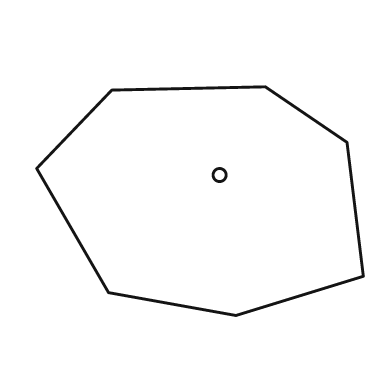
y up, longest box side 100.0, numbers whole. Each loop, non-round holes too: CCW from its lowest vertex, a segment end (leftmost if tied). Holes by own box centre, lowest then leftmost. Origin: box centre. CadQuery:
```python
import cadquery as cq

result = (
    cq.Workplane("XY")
    .moveTo(11.0, -35.0)
    .lineTo(50.0, -23.0)
    .lineTo(45.0, 18.0)
    .lineTo(20.0, 35.0)
    .lineTo(-27.0, 34.0)
    .lineTo(-50.0, 10.0)
    .lineTo(-28.0, -28.0)
    .close()
    .moveTo(6.0, 8.0)
    .circle(2.0)
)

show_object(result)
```